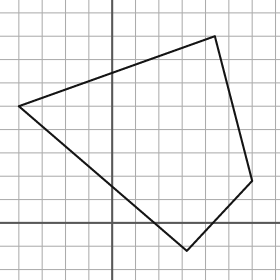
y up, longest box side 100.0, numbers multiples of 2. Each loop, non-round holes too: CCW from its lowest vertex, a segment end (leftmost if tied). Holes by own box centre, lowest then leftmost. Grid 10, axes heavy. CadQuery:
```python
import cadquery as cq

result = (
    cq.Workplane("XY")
    .moveTo(32.0, -12.0)
    .lineTo(60.0, 18.0)
    .lineTo(44.0, 80.0)
    .lineTo(-40.0, 50.0)
    .close()
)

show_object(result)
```